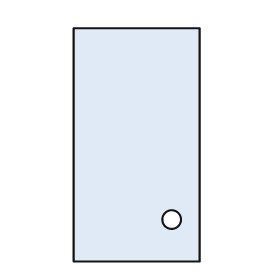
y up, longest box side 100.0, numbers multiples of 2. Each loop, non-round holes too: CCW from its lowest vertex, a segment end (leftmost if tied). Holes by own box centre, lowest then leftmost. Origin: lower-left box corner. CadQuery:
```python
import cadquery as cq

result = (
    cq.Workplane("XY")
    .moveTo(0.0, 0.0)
    .lineTo(54.0, 0.0)
    .lineTo(54.0, 100.0)
    .lineTo(0.0, 100.0)
    .close()
    .moveTo(42.0, 18.0)
    .circle(4.0)
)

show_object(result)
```